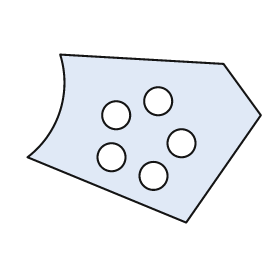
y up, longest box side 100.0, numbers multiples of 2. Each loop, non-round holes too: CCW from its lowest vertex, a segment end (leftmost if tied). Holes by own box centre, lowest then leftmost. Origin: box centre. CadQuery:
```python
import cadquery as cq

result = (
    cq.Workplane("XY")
    .moveTo(18.0, -36.0)
    .lineTo(50.0, 10.0)
    .lineTo(34.0, 32.0)
    .lineTo(-36.0, 36.0)
    .threePointArc((-36.0, 12.0), (-50.0, -8.0))
    .close()
    .moveTo(4.0, -16.0)
    .circle(6.0)
    .moveTo(-14.0, -8.0)
    .circle(6.0)
    .moveTo(16.0, -2.0)
    .circle(6.0)
    .moveTo(-12.0, 10.0)
    .circle(6.0)
    .moveTo(6.0, 16.0)
    .circle(6.0)
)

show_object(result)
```